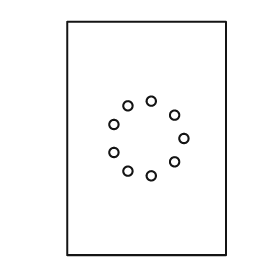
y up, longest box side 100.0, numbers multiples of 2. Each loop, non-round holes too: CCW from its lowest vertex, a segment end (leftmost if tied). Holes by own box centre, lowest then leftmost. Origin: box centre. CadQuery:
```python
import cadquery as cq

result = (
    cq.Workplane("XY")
    .moveTo(-34.0, -50.0)
    .lineTo(34.0, -50.0)
    .lineTo(34.0, 50.0)
    .lineTo(-34.0, 50.0)
    .close()
    .moveTo(2.0, -16.0)
    .circle(2.0)
    .moveTo(-8.0, -14.0)
    .circle(2.0)
    .moveTo(12.0, -10.0)
    .circle(2.0)
    .moveTo(-14.0, -6.0)
    .circle(2.0)
    .moveTo(16.0, 0.0)
    .circle(2.0)
    .moveTo(-14.0, 6.0)
    .circle(2.0)
    .moveTo(12.0, 10.0)
    .circle(2.0)
    .moveTo(-8.0, 14.0)
    .circle(2.0)
    .moveTo(2.0, 16.0)
    .circle(2.0)
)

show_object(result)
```